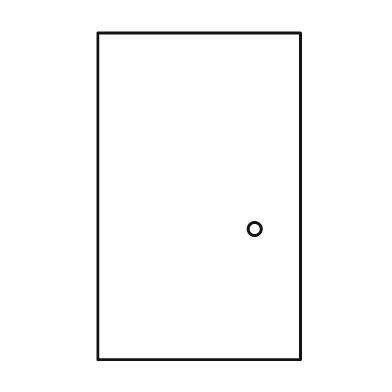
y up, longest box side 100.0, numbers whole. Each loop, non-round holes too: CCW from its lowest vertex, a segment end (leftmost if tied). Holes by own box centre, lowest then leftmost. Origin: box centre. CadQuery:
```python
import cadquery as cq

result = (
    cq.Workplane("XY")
    .moveTo(-31.0, -50.0)
    .lineTo(31.0, -50.0)
    .lineTo(31.0, 50.0)
    .lineTo(-31.0, 50.0)
    .close()
    .moveTo(17.0, -10.0)
    .circle(2.0)
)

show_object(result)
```